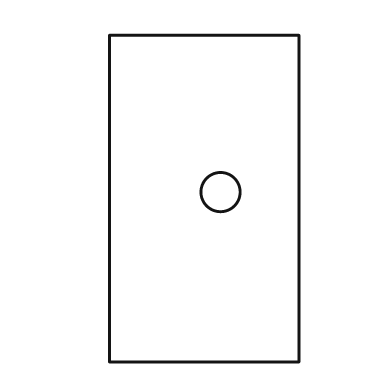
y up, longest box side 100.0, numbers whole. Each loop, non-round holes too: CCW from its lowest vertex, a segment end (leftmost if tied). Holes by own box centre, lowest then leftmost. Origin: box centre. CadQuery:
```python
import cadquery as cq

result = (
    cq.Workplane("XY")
    .moveTo(-29.0, -50.0)
    .lineTo(29.0, -50.0)
    .lineTo(29.0, 50.0)
    .lineTo(-29.0, 50.0)
    .close()
    .moveTo(5.0, 2.0)
    .circle(6.0)
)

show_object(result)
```